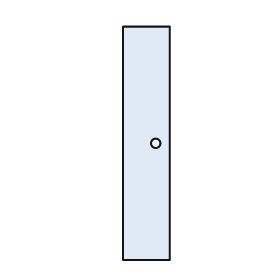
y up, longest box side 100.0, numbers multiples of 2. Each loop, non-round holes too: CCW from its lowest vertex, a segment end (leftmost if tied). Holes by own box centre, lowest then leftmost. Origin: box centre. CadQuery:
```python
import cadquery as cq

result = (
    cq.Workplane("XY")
    .moveTo(-10.0, -50.0)
    .lineTo(10.0, -50.0)
    .lineTo(10.0, 50.0)
    .lineTo(-10.0, 50.0)
    .close()
    .moveTo(4.0, 0.0)
    .circle(2.0)
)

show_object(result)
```